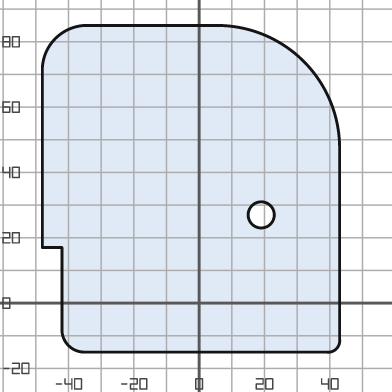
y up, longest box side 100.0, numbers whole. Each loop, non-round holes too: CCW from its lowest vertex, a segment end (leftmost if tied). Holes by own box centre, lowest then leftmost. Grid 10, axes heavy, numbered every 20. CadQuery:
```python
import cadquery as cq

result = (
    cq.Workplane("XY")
    .moveTo(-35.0, -15.0)
    .lineTo(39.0, -15.0)
    .threePointArc((42.0, -14.0), (43.0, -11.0))
    .lineTo(43.0, 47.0)
    .threePointArc((32.0, 74.0), (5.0, 85.0))
    .lineTo(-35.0, 85.0)
    .threePointArc((-44.0, 81.0), (-48.0, 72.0))
    .lineTo(-48.0, 17.0)
    .lineTo(-42.0, 17.0)
    .lineTo(-42.0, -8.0)
    .threePointArc((-40.0, -13.0), (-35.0, -15.0))
    .close()
    .moveTo(19.0, 27.0)
    .circle(4.0)
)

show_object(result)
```